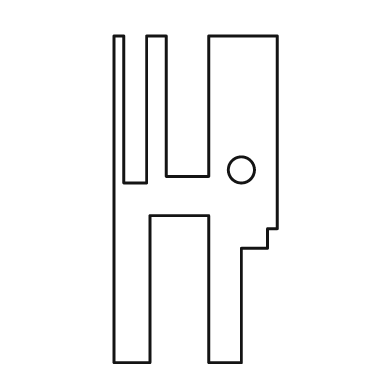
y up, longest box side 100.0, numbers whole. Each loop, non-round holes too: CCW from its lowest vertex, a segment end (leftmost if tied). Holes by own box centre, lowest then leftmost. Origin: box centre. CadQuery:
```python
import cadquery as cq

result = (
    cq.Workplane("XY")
    .moveTo(-25.0, -50.0)
    .lineTo(-14.0, -50.0)
    .lineTo(-14.0, -5.0)
    .lineTo(4.0, -5.0)
    .lineTo(4.0, -50.0)
    .lineTo(14.0, -50.0)
    .lineTo(14.0, -15.0)
    .lineTo(22.0, -15.0)
    .lineTo(22.0, -9.0)
    .lineTo(25.0, -9.0)
    .lineTo(25.0, 50.0)
    .lineTo(4.0, 50.0)
    .lineTo(4.0, 7.0)
    .lineTo(-9.0, 7.0)
    .lineTo(-9.0, 50.0)
    .lineTo(-15.0, 50.0)
    .lineTo(-15.0, 5.0)
    .lineTo(-22.0, 5.0)
    .lineTo(-22.0, 50.0)
    .lineTo(-25.0, 50.0)
    .close()
    .moveTo(14.0, 9.0)
    .circle(4.0)
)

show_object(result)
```